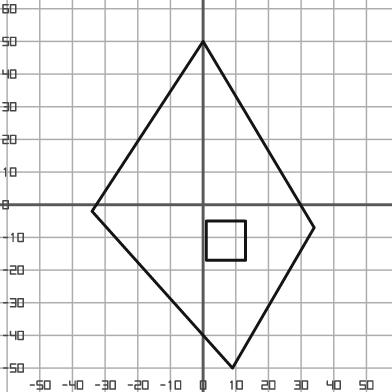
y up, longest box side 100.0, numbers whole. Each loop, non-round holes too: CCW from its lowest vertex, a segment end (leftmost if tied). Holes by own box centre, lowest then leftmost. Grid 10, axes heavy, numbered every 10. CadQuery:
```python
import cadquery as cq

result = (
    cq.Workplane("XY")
    .moveTo(9.0, -50.0)
    .lineTo(34.0, -7.0)
    .lineTo(0.0, 50.0)
    .lineTo(-34.0, -2.0)
    .close()
    .moveTo(1.0, -17.0)
    .lineTo(13.0, -17.0)
    .lineTo(13.0, -5.0)
    .lineTo(1.0, -5.0)
    .close()
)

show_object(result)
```